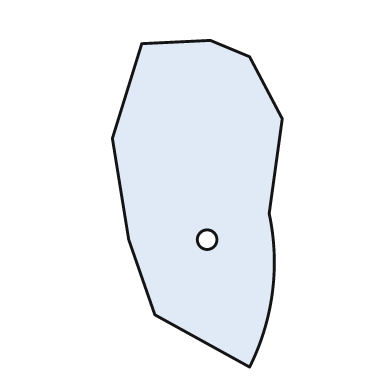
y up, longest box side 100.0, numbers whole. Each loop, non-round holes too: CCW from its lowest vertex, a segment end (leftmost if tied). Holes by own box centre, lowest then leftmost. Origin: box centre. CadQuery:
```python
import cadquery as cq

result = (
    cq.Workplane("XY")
    .moveTo(16.0, -50.0)
    .threePointArc((23.0, -27.0), (22.0, -3.0))
    .lineTo(26.0, 26.0)
    .lineTo(16.0, 45.0)
    .lineTo(4.0, 50.0)
    .lineTo(-17.0, 49.0)
    .lineTo(-26.0, 20.0)
    .lineTo(-21.0, -11.0)
    .lineTo(-13.0, -34.0)
    .close()
    .moveTo(3.0, -11.0)
    .circle(3.0)
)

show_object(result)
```